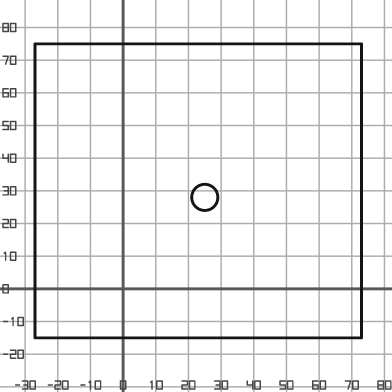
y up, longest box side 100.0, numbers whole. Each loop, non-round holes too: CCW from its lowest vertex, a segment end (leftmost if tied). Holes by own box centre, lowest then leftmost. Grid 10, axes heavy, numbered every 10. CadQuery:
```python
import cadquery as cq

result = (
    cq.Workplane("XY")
    .moveTo(-27.0, -15.0)
    .lineTo(73.0, -15.0)
    .lineTo(73.0, 75.0)
    .lineTo(-27.0, 75.0)
    .close()
    .moveTo(25.0, 28.0)
    .circle(4.0)
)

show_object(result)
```